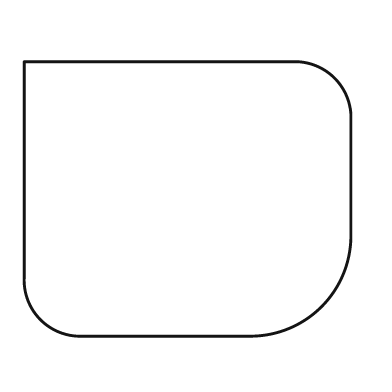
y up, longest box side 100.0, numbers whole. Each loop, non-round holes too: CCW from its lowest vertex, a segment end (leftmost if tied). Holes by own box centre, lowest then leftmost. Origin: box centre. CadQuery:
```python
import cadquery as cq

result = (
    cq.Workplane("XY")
    .moveTo(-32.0, -42.0)
    .lineTo(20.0, -42.0)
    .threePointArc((41.0, -33.0), (50.0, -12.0))
    .lineTo(50.0, 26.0)
    .threePointArc((45.0, 37.0), (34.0, 42.0))
    .lineTo(-50.0, 42.0)
    .lineTo(-50.0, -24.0)
    .threePointArc((-45.0, -37.0), (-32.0, -42.0))
    .close()
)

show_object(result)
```